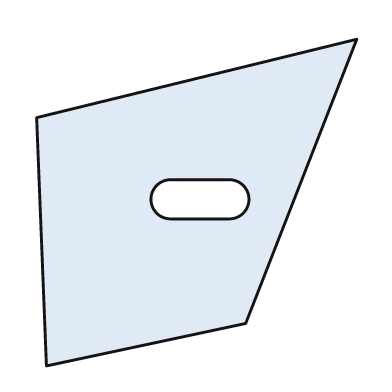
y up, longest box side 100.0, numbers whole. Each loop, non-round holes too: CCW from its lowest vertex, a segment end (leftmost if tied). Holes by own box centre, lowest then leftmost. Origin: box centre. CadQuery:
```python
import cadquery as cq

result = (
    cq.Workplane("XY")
    .moveTo(-46.0, -50.0)
    .lineTo(15.0, -37.0)
    .lineTo(49.0, 50.0)
    .lineTo(-49.0, 26.0)
    .close()
    .moveTo(-8.0, -5.0)
    .lineTo(10.0, -5.0)
    .threePointArc((16.0, 1.0), (10.0, 7.0))
    .lineTo(-8.0, 7.0)
    .threePointArc((-14.0, 1.0), (-8.0, -5.0))
    .close()
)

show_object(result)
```